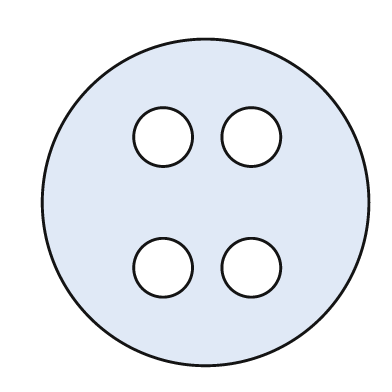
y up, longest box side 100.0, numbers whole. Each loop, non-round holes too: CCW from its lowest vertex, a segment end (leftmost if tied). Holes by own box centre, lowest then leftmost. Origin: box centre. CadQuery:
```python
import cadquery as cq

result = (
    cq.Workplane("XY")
    .moveTo(0.0, 0.0)
    .circle(50.0)
    .moveTo(-13.0, -20.0)
    .circle(9.0)
    .moveTo(14.0, -20.0)
    .circle(9.0)
    .moveTo(-13.0, 20.0)
    .circle(9.0)
    .moveTo(14.0, 20.0)
    .circle(9.0)
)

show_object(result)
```